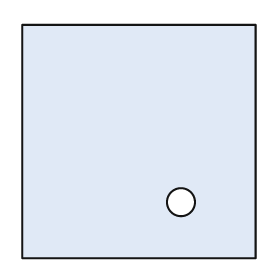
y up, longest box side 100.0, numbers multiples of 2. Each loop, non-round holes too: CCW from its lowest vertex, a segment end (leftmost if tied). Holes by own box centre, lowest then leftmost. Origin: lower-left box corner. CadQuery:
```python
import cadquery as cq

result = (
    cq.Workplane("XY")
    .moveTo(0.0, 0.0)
    .lineTo(100.0, 0.0)
    .lineTo(100.0, 100.0)
    .lineTo(0.0, 100.0)
    .close()
    .moveTo(68.0, 24.0)
    .circle(6.0)
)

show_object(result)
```